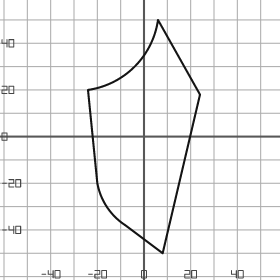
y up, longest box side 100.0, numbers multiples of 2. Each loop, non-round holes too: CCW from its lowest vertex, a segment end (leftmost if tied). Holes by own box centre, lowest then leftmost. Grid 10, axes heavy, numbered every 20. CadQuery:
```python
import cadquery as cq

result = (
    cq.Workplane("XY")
    .moveTo(8.0, -50.0)
    .lineTo(24.0, 18.0)
    .lineTo(6.0, 50.0)
    .threePointArc((-4.0, 30.0), (-24.0, 20.0))
    .lineTo(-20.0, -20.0)
    .threePointArc((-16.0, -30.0), (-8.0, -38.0))
    .close()
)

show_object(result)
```